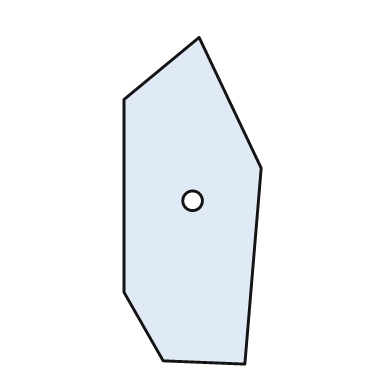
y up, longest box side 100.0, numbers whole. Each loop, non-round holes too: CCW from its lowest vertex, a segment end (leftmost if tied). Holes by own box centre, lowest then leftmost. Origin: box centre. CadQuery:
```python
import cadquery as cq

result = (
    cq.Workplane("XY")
    .moveTo(16.0, -50.0)
    .lineTo(21.0, 10.0)
    .lineTo(2.0, 50.0)
    .lineTo(-21.0, 31.0)
    .lineTo(-21.0, -28.0)
    .lineTo(-9.0, -49.0)
    .close()
    .moveTo(0.0, 0.0)
    .circle(3.0)
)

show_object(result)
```